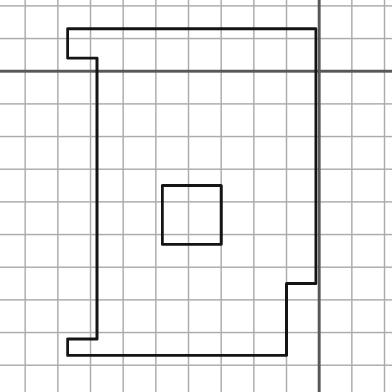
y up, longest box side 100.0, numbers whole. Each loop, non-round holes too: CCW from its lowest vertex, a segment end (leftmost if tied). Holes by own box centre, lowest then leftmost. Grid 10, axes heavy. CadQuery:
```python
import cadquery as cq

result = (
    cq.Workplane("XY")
    .moveTo(-77.0, -87.0)
    .lineTo(-10.0, -87.0)
    .lineTo(-10.0, -65.0)
    .lineTo(-1.0, -65.0)
    .lineTo(-1.0, 13.0)
    .lineTo(-77.0, 13.0)
    .lineTo(-77.0, 4.0)
    .lineTo(-68.0, 4.0)
    .lineTo(-68.0, -82.0)
    .lineTo(-77.0, -82.0)
    .close()
    .moveTo(-48.0, -53.0)
    .lineTo(-30.0, -53.0)
    .lineTo(-30.0, -35.0)
    .lineTo(-48.0, -35.0)
    .close()
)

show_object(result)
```